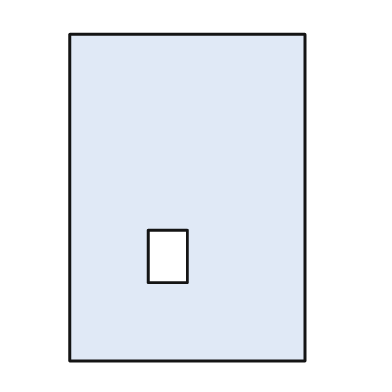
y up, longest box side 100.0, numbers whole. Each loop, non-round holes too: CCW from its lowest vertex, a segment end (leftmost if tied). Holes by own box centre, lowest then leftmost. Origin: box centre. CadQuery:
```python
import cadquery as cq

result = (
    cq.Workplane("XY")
    .moveTo(-36.0, -50.0)
    .lineTo(36.0, -50.0)
    .lineTo(36.0, 50.0)
    .lineTo(-36.0, 50.0)
    .close()
    .moveTo(-12.0, -26.0)
    .lineTo(0.0, -26.0)
    .lineTo(0.0, -10.0)
    .lineTo(-12.0, -10.0)
    .close()
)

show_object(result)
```